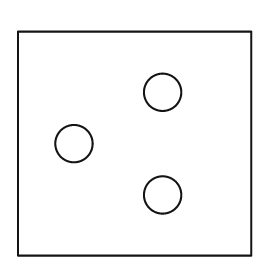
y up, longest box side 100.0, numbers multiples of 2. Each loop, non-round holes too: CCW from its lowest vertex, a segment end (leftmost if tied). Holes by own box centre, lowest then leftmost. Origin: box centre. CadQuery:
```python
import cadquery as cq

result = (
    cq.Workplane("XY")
    .moveTo(-50.0, -48.0)
    .lineTo(50.0, -48.0)
    .lineTo(50.0, 48.0)
    .lineTo(-50.0, 48.0)
    .close()
    .moveTo(12.0, -22.0)
    .circle(8.0)
    .moveTo(-26.0, 0.0)
    .circle(8.0)
    .moveTo(12.0, 22.0)
    .circle(8.0)
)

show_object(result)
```